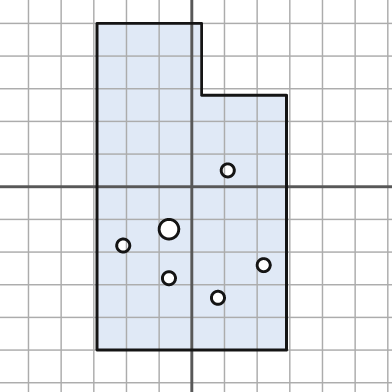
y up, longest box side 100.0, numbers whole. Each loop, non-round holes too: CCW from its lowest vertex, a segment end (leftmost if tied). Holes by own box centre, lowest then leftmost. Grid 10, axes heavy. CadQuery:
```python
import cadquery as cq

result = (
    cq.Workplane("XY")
    .moveTo(-29.0, -50.0)
    .lineTo(29.0, -50.0)
    .lineTo(29.0, 28.0)
    .lineTo(3.0, 28.0)
    .lineTo(3.0, 50.0)
    .lineTo(-29.0, 50.0)
    .close()
    .moveTo(8.0, -34.0)
    .circle(2.0)
    .moveTo(-7.0, -28.0)
    .circle(2.0)
    .moveTo(22.0, -24.0)
    .circle(2.0)
    .moveTo(-21.0, -18.0)
    .circle(2.0)
    .moveTo(-7.0, -13.0)
    .circle(3.0)
    .moveTo(11.0, 5.0)
    .circle(2.0)
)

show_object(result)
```